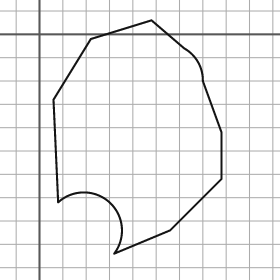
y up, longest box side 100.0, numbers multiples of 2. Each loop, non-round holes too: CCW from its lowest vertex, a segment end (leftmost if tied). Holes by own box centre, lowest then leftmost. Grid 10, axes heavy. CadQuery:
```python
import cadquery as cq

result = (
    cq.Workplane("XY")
    .moveTo(32.0, -94.0)
    .lineTo(56.0, -84.0)
    .lineTo(78.0, -62.0)
    .lineTo(78.0, -42.0)
    .lineTo(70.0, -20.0)
    .threePointArc((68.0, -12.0), (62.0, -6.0))
    .lineTo(48.0, 6.0)
    .lineTo(22.0, -2.0)
    .lineTo(6.0, -28.0)
    .lineTo(8.0, -72.0)
    .threePointArc((30.0, -72.0), (32.0, -94.0))
    .close()
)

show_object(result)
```